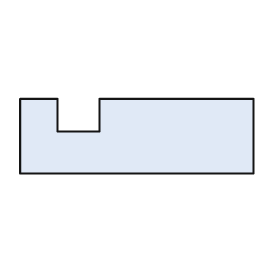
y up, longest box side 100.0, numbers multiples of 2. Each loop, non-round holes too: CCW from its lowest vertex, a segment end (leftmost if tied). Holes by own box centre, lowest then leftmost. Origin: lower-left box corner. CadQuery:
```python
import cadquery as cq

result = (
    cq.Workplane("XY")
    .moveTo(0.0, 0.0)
    .lineTo(100.0, 0.0)
    .lineTo(100.0, 32.0)
    .lineTo(34.0, 32.0)
    .lineTo(34.0, 18.0)
    .lineTo(16.0, 18.0)
    .lineTo(16.0, 32.0)
    .lineTo(0.0, 32.0)
    .close()
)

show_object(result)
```